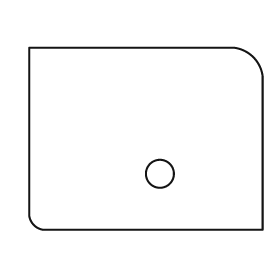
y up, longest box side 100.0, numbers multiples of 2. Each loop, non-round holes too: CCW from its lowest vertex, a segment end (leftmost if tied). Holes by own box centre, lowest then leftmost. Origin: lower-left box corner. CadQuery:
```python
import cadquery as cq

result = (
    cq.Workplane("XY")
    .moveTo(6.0, 0.0)
    .lineTo(100.0, 0.0)
    .lineTo(100.0, 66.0)
    .threePointArc((96.0, 74.0), (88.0, 78.0))
    .lineTo(0.0, 78.0)
    .lineTo(0.0, 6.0)
    .threePointArc((2.0, 2.0), (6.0, 0.0))
    .close()
    .moveTo(56.0, 24.0)
    .circle(6.0)
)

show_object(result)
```